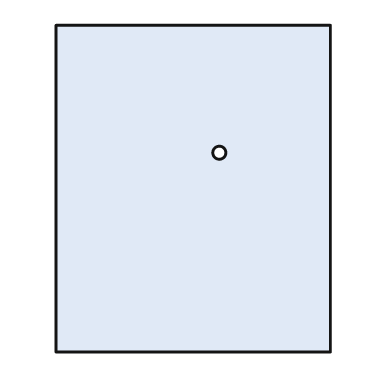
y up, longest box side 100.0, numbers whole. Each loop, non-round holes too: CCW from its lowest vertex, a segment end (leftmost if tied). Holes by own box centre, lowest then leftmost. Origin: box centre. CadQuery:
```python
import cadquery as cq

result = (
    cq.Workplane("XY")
    .moveTo(-42.0, -50.0)
    .lineTo(42.0, -50.0)
    .lineTo(42.0, 50.0)
    .lineTo(-42.0, 50.0)
    .close()
    .moveTo(8.0, 11.0)
    .circle(2.0)
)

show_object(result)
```